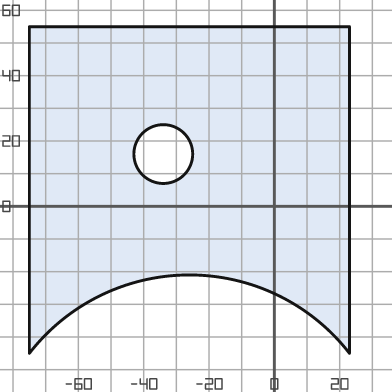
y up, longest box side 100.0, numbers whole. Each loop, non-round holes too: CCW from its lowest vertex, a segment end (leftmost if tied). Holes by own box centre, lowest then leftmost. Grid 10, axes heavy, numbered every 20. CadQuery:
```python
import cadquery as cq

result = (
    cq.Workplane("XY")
    .moveTo(-75.0, -45.0)
    .threePointArc((-26.0, -21.0), (23.0, -45.0))
    .lineTo(23.0, 55.0)
    .lineTo(-75.0, 55.0)
    .close()
    .moveTo(-34.0, 16.0)
    .circle(9.0)
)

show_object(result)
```